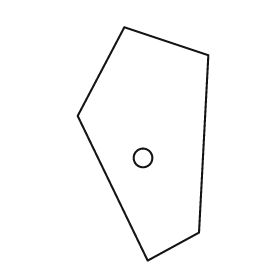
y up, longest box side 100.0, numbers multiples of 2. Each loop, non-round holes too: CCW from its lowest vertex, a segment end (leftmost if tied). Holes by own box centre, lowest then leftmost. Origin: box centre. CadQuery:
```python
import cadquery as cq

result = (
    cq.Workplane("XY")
    .moveTo(2.0, -50.0)
    .lineTo(24.0, -38.0)
    .lineTo(28.0, 38.0)
    .lineTo(-8.0, 50.0)
    .lineTo(-28.0, 12.0)
    .close()
    .moveTo(0.0, -6.0)
    .circle(4.0)
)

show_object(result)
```